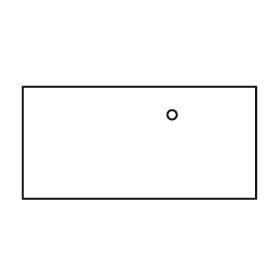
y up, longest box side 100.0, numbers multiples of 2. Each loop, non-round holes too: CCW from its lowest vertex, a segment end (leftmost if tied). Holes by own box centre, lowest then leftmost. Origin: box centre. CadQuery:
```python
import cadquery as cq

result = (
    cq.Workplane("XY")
    .moveTo(-50.0, -24.0)
    .lineTo(50.0, -24.0)
    .lineTo(50.0, 24.0)
    .lineTo(-50.0, 24.0)
    .close()
    .moveTo(14.0, 12.0)
    .circle(2.0)
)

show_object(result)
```